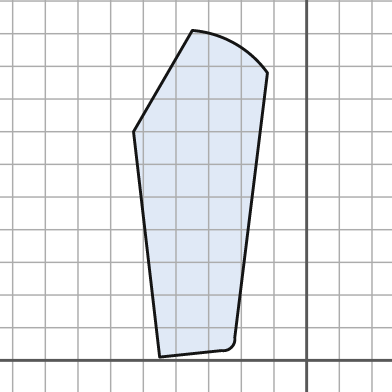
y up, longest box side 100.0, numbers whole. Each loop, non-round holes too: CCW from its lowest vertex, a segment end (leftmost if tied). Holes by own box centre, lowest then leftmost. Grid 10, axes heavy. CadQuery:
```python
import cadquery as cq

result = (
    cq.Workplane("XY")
    .moveTo(-45.0, 1.0)
    .lineTo(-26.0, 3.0)
    .threePointArc((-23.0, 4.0), (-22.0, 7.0))
    .lineTo(-12.0, 88.0)
    .threePointArc((-22.0, 97.0), (-35.0, 101.0))
    .lineTo(-53.0, 70.0)
    .close()
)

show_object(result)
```